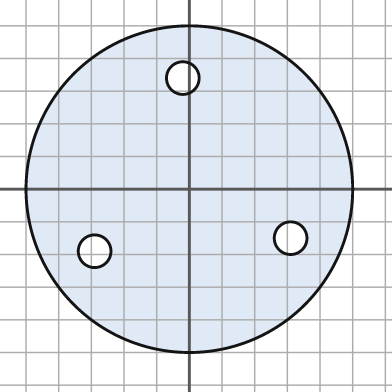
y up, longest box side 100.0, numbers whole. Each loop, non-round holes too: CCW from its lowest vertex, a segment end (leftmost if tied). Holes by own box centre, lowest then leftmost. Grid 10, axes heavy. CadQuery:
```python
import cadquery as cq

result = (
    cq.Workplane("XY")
    .moveTo(0.0, 0.0)
    .circle(50.0)
    .moveTo(-29.0, -19.0)
    .circle(5.0)
    .moveTo(31.0, -15.0)
    .circle(5.0)
    .moveTo(-2.0, 34.0)
    .circle(5.0)
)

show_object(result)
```